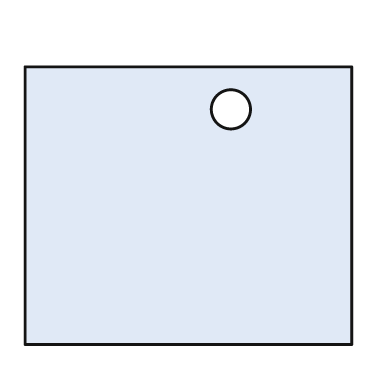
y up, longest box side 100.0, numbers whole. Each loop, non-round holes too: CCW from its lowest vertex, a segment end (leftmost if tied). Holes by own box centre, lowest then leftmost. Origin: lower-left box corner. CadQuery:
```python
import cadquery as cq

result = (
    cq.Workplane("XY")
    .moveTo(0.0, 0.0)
    .lineTo(100.0, 0.0)
    .lineTo(100.0, 85.0)
    .lineTo(0.0, 85.0)
    .close()
    .moveTo(63.0, 72.0)
    .circle(6.0)
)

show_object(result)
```